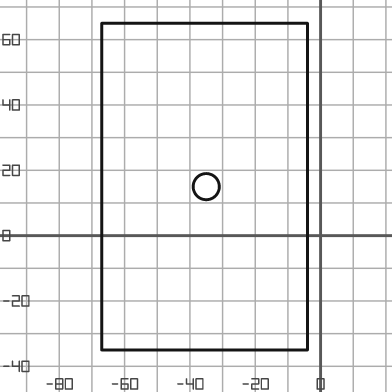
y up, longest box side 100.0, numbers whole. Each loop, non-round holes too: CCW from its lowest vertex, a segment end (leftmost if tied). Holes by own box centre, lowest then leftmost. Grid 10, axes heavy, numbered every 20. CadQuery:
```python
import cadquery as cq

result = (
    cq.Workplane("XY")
    .moveTo(-67.0, -35.0)
    .lineTo(-4.0, -35.0)
    .lineTo(-4.0, 65.0)
    .lineTo(-67.0, 65.0)
    .close()
    .moveTo(-35.0, 15.0)
    .circle(4.0)
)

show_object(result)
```